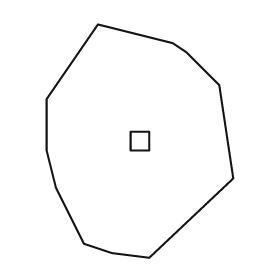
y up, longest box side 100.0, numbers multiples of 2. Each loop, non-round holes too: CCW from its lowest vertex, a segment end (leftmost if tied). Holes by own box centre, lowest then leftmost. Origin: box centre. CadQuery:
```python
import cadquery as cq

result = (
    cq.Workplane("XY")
    .moveTo(4.0, -50.0)
    .lineTo(40.0, -16.0)
    .lineTo(34.0, 24.0)
    .lineTo(20.0, 38.0)
    .lineTo(14.0, 42.0)
    .lineTo(-18.0, 50.0)
    .lineTo(-40.0, 18.0)
    .lineTo(-40.0, -4.0)
    .lineTo(-36.0, -20.0)
    .lineTo(-24.0, -44.0)
    .lineTo(-12.0, -48.0)
    .close()
    .moveTo(-4.0, -4.0)
    .lineTo(4.0, -4.0)
    .lineTo(4.0, 4.0)
    .lineTo(-4.0, 4.0)
    .close()
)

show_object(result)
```